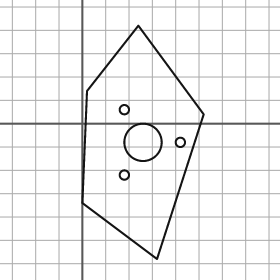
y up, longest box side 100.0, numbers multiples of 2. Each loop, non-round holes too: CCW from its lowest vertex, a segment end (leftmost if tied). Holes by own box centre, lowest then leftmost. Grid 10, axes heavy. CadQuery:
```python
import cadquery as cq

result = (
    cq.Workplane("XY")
    .moveTo(32.0, -58.0)
    .lineTo(52.0, 4.0)
    .lineTo(24.0, 42.0)
    .lineTo(2.0, 14.0)
    .lineTo(0.0, -34.0)
    .close()
    .moveTo(18.0, -22.0)
    .circle(2.0)
    .moveTo(26.0, -8.0)
    .circle(8.0)
    .moveTo(42.0, -8.0)
    .circle(2.0)
    .moveTo(18.0, 6.0)
    .circle(2.0)
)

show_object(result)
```